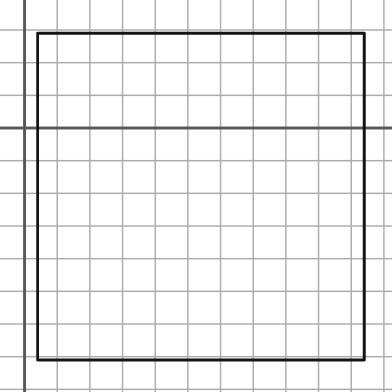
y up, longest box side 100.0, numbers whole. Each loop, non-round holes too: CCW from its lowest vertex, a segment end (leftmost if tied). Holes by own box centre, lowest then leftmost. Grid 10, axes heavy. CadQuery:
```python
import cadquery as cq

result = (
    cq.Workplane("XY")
    .moveTo(4.0, -71.0)
    .lineTo(104.0, -71.0)
    .lineTo(104.0, 29.0)
    .lineTo(4.0, 29.0)
    .close()
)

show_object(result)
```